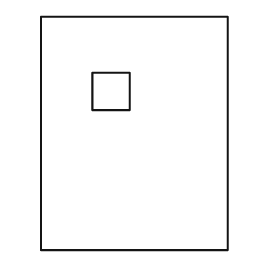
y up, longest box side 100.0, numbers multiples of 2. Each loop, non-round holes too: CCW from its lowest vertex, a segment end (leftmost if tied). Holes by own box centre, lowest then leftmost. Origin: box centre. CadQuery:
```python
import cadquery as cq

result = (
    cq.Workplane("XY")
    .moveTo(-40.0, -50.0)
    .lineTo(40.0, -50.0)
    .lineTo(40.0, 50.0)
    .lineTo(-40.0, 50.0)
    .close()
    .moveTo(-18.0, 10.0)
    .lineTo(-2.0, 10.0)
    .lineTo(-2.0, 26.0)
    .lineTo(-18.0, 26.0)
    .close()
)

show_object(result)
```